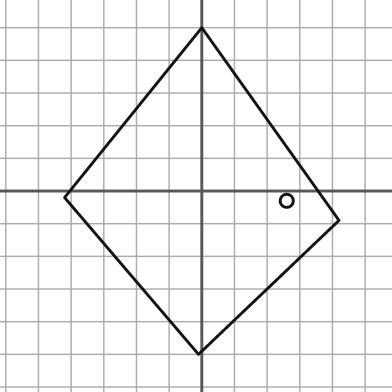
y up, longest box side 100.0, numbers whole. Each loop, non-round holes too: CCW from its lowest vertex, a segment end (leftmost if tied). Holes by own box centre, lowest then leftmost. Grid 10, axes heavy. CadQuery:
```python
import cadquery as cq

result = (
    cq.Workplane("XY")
    .moveTo(-1.0, -50.0)
    .lineTo(42.0, -9.0)
    .lineTo(0.0, 50.0)
    .lineTo(-42.0, -2.0)
    .close()
    .moveTo(26.0, -3.0)
    .circle(2.0)
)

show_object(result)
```